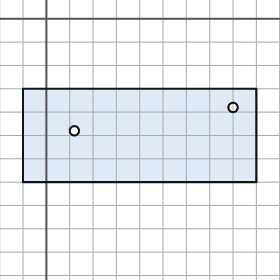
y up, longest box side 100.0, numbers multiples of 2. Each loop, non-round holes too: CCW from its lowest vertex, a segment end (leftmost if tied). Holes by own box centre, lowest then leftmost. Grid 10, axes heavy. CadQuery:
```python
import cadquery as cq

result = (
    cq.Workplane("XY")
    .moveTo(-10.0, -70.0)
    .lineTo(90.0, -70.0)
    .lineTo(90.0, -30.0)
    .lineTo(-10.0, -30.0)
    .close()
    .moveTo(12.0, -48.0)
    .circle(2.0)
    .moveTo(80.0, -38.0)
    .circle(2.0)
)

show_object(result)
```